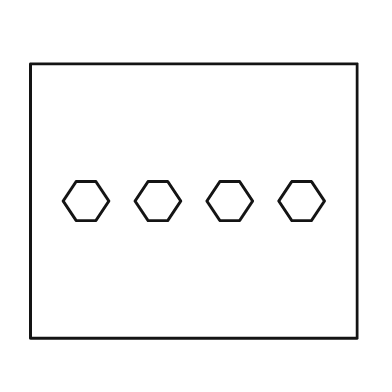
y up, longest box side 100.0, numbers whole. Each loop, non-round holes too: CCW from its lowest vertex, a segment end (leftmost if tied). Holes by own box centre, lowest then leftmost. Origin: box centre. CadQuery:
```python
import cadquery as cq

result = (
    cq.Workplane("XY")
    .moveTo(-50.0, -42.0)
    .lineTo(50.0, -42.0)
    .lineTo(50.0, 42.0)
    .lineTo(-50.0, 42.0)
    .close()
    .moveTo(-36.0, -6.0)
    .lineTo(-30.0, -6.0)
    .lineTo(-26.0, 0.0)
    .lineTo(-30.0, 6.0)
    .lineTo(-36.0, 6.0)
    .lineTo(-40.0, 0.0)
    .close()
    .moveTo(-14.0, -6.0)
    .lineTo(-8.0, -6.0)
    .lineTo(-4.0, 0.0)
    .lineTo(-8.0, 6.0)
    .lineTo(-14.0, 6.0)
    .lineTo(-18.0, 0.0)
    .close()
    .moveTo(8.0, -6.0)
    .lineTo(14.0, -6.0)
    .lineTo(18.0, 0.0)
    .lineTo(14.0, 6.0)
    .lineTo(8.0, 6.0)
    .lineTo(4.0, 0.0)
    .close()
    .moveTo(30.0, -6.0)
    .lineTo(36.0, -6.0)
    .lineTo(40.0, 0.0)
    .lineTo(36.0, 6.0)
    .lineTo(30.0, 6.0)
    .lineTo(26.0, 0.0)
    .close()
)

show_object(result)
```